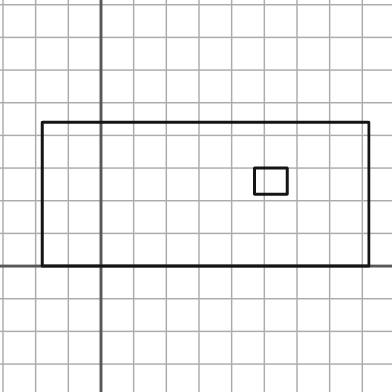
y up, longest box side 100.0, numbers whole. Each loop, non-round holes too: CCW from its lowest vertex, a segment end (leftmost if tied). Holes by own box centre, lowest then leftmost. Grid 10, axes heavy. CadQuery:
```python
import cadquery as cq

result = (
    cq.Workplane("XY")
    .moveTo(-18.0, 0.0)
    .lineTo(82.0, 0.0)
    .lineTo(82.0, 44.0)
    .lineTo(-18.0, 44.0)
    .close()
    .moveTo(47.0, 22.0)
    .lineTo(57.0, 22.0)
    .lineTo(57.0, 30.0)
    .lineTo(47.0, 30.0)
    .close()
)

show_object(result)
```